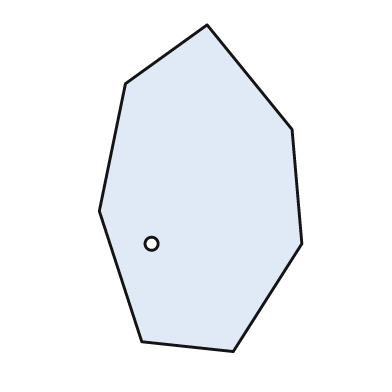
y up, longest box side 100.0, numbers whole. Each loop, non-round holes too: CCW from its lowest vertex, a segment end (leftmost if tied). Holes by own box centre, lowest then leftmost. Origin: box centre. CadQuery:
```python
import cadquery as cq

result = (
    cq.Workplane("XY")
    .moveTo(10.0, -50.0)
    .lineTo(31.0, -17.0)
    .lineTo(28.0, 18.0)
    .lineTo(2.0, 50.0)
    .lineTo(-23.0, 32.0)
    .lineTo(-31.0, -7.0)
    .lineTo(-18.0, -47.0)
    .close()
    .moveTo(-15.0, -17.0)
    .circle(2.0)
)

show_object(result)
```